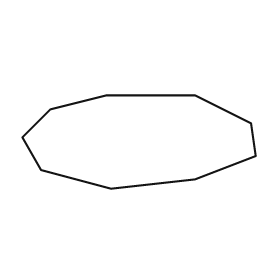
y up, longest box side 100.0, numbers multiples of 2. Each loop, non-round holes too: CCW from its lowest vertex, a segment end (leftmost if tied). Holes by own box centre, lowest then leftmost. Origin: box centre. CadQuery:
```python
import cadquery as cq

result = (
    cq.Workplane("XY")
    .moveTo(-12.0, -20.0)
    .lineTo(24.0, -16.0)
    .lineTo(50.0, -6.0)
    .lineTo(48.0, 8.0)
    .lineTo(24.0, 20.0)
    .lineTo(-14.0, 20.0)
    .lineTo(-38.0, 14.0)
    .lineTo(-50.0, 2.0)
    .lineTo(-42.0, -12.0)
    .close()
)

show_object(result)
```